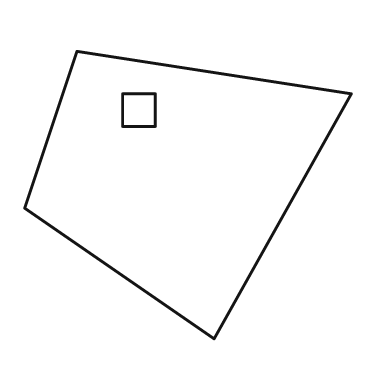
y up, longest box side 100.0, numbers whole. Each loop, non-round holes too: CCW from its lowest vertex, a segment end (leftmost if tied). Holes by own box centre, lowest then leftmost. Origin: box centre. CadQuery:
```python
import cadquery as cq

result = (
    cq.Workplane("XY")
    .moveTo(8.0, -44.0)
    .lineTo(50.0, 31.0)
    .lineTo(-34.0, 44.0)
    .lineTo(-50.0, -4.0)
    .close()
    .moveTo(-20.0, 21.0)
    .lineTo(-10.0, 21.0)
    .lineTo(-10.0, 31.0)
    .lineTo(-20.0, 31.0)
    .close()
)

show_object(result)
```